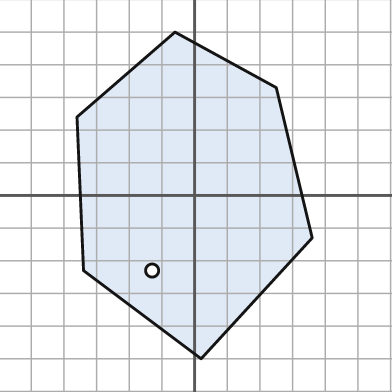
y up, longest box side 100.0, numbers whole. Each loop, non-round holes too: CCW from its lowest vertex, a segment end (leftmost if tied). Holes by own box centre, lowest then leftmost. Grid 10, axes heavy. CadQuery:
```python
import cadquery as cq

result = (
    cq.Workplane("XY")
    .moveTo(2.0, -50.0)
    .lineTo(36.0, -13.0)
    .lineTo(25.0, 33.0)
    .lineTo(-6.0, 50.0)
    .lineTo(-36.0, 24.0)
    .lineTo(-34.0, -23.0)
    .close()
    .moveTo(-13.0, -23.0)
    .circle(2.0)
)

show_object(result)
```